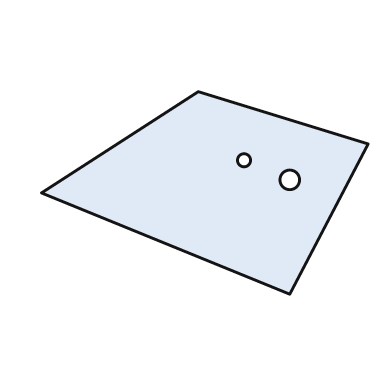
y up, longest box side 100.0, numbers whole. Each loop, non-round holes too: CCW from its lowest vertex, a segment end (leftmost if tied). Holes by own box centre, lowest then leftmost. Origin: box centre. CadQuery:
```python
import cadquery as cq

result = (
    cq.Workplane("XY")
    .moveTo(26.0, -31.0)
    .lineTo(50.0, 15.0)
    .lineTo(-2.0, 31.0)
    .lineTo(-50.0, 0.0)
    .close()
    .moveTo(26.0, 4.0)
    .circle(3.0)
    .moveTo(12.0, 10.0)
    .circle(2.0)
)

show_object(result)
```